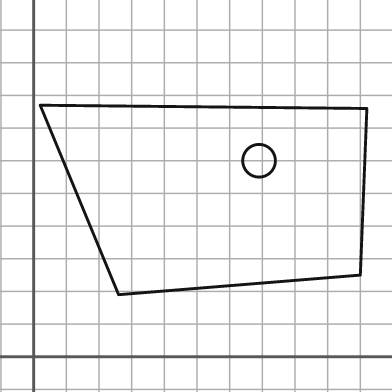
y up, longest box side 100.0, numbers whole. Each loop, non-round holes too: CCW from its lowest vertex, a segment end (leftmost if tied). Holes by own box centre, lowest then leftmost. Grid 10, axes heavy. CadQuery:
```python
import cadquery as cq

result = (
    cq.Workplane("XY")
    .moveTo(26.0, 19.0)
    .lineTo(100.0, 25.0)
    .lineTo(102.0, 76.0)
    .lineTo(2.0, 77.0)
    .close()
    .moveTo(69.0, 60.0)
    .circle(5.0)
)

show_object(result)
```